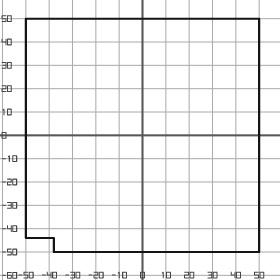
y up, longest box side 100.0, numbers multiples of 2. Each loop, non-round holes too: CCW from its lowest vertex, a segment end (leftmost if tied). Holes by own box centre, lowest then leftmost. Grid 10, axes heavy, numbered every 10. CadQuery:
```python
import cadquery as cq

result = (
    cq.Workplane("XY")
    .moveTo(-38.0, -50.0)
    .lineTo(50.0, -50.0)
    .lineTo(50.0, 50.0)
    .lineTo(-50.0, 50.0)
    .lineTo(-50.0, -44.0)
    .lineTo(-38.0, -44.0)
    .close()
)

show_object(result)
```